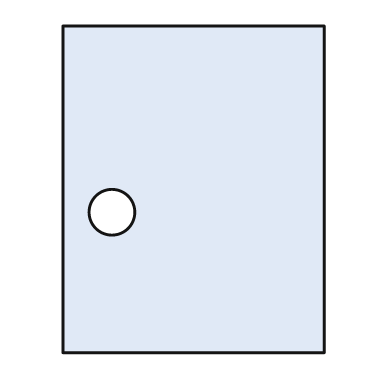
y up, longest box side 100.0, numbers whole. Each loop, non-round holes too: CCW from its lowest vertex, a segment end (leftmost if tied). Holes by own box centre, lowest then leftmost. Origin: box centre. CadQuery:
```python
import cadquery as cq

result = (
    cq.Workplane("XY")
    .moveTo(-40.0, -50.0)
    .lineTo(40.0, -50.0)
    .lineTo(40.0, 50.0)
    .lineTo(-40.0, 50.0)
    .close()
    .moveTo(-25.0, -7.0)
    .circle(7.0)
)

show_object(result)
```